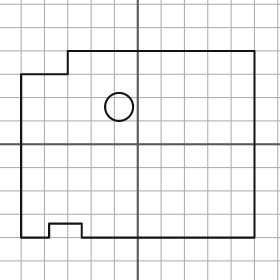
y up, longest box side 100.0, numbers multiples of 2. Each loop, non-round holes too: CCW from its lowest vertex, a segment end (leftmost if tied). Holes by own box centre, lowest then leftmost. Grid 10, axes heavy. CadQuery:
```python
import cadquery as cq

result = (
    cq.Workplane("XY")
    .moveTo(-50.0, -40.0)
    .lineTo(-38.0, -40.0)
    .lineTo(-38.0, -34.0)
    .lineTo(-24.0, -34.0)
    .lineTo(-24.0, -40.0)
    .lineTo(50.0, -40.0)
    .lineTo(50.0, 40.0)
    .lineTo(-30.0, 40.0)
    .lineTo(-30.0, 30.0)
    .lineTo(-50.0, 30.0)
    .close()
    .moveTo(-8.0, 16.0)
    .circle(6.0)
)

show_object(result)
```